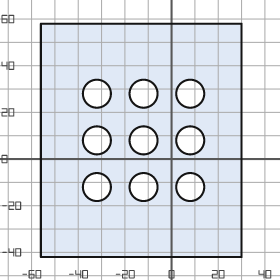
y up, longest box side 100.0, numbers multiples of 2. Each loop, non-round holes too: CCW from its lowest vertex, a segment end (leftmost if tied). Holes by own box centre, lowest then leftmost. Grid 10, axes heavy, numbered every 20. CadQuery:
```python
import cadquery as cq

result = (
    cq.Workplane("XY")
    .moveTo(-56.0, -42.0)
    .lineTo(30.0, -42.0)
    .lineTo(30.0, 58.0)
    .lineTo(-56.0, 58.0)
    .close()
    .moveTo(-32.0, -12.0)
    .circle(6.0)
    .moveTo(-12.0, -12.0)
    .circle(6.0)
    .moveTo(8.0, -12.0)
    .circle(6.0)
    .moveTo(-32.0, 8.0)
    .circle(6.0)
    .moveTo(-12.0, 8.0)
    .circle(6.0)
    .moveTo(8.0, 8.0)
    .circle(6.0)
    .moveTo(-32.0, 28.0)
    .circle(6.0)
    .moveTo(-12.0, 28.0)
    .circle(6.0)
    .moveTo(8.0, 28.0)
    .circle(6.0)
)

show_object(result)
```